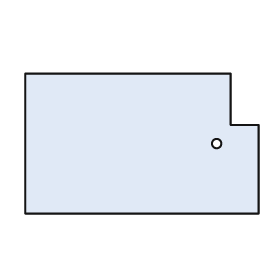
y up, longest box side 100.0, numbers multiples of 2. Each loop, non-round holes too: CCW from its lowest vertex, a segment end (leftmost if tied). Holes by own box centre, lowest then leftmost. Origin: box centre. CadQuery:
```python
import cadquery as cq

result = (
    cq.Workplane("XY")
    .moveTo(-50.0, -30.0)
    .lineTo(50.0, -30.0)
    .lineTo(50.0, 8.0)
    .lineTo(38.0, 8.0)
    .lineTo(38.0, 30.0)
    .lineTo(-50.0, 30.0)
    .close()
    .moveTo(32.0, 0.0)
    .circle(2.0)
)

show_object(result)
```